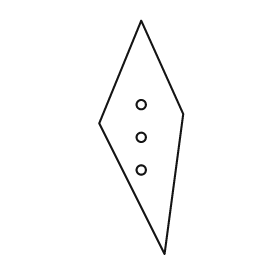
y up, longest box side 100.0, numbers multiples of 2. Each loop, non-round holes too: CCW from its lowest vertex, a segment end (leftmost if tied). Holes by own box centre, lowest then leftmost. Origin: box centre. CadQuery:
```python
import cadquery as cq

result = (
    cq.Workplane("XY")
    .moveTo(10.0, -50.0)
    .lineTo(18.0, 10.0)
    .lineTo(0.0, 50.0)
    .lineTo(-18.0, 6.0)
    .close()
    .moveTo(0.0, -14.0)
    .circle(2.0)
    .moveTo(0.0, 0.0)
    .circle(2.0)
    .moveTo(0.0, 14.0)
    .circle(2.0)
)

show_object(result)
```